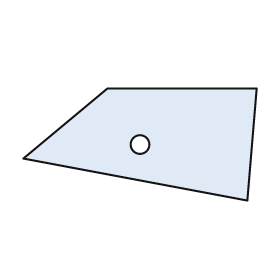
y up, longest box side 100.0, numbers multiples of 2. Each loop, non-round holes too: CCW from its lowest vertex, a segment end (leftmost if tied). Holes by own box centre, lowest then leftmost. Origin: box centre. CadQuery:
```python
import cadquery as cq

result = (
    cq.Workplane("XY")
    .moveTo(46.0, -24.0)
    .lineTo(50.0, 24.0)
    .lineTo(-14.0, 24.0)
    .lineTo(-50.0, -6.0)
    .close()
    .moveTo(0.0, 0.0)
    .circle(4.0)
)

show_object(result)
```